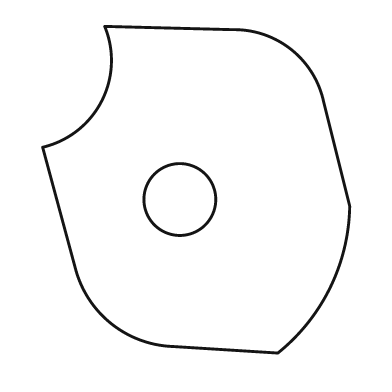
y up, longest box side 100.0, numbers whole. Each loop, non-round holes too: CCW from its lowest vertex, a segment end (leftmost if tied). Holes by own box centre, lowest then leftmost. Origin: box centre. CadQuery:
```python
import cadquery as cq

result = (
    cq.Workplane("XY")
    .moveTo(25.0, -50.0)
    .threePointArc((41.0, -30.0), (47.0, -5.0))
    .lineTo(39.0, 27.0)
    .threePointArc((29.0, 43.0), (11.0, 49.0))
    .lineTo(-28.0, 50.0)
    .threePointArc((-29.0, 27.0), (-47.0, 13.0))
    .lineTo(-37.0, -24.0)
    .threePointArc((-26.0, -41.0), (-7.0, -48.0))
    .close()
    .moveTo(-5.0, -3.0)
    .circle(11.0)
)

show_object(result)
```